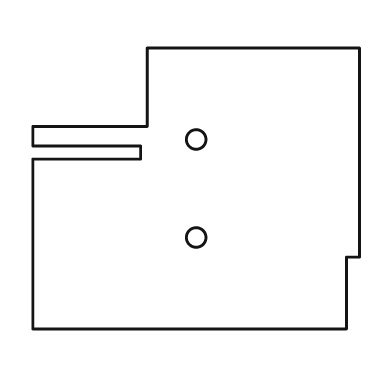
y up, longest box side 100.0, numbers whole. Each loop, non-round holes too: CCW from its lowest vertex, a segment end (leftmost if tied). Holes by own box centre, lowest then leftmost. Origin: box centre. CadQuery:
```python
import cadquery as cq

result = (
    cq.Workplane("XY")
    .moveTo(-50.0, -43.0)
    .lineTo(46.0, -43.0)
    .lineTo(46.0, -21.0)
    .lineTo(50.0, -21.0)
    .lineTo(50.0, 43.0)
    .lineTo(-15.0, 43.0)
    .lineTo(-15.0, 19.0)
    .lineTo(-50.0, 19.0)
    .lineTo(-50.0, 13.0)
    .lineTo(-17.0, 13.0)
    .lineTo(-17.0, 9.0)
    .lineTo(-50.0, 9.0)
    .close()
    .moveTo(0.0, -15.0)
    .circle(3.0)
    .moveTo(0.0, 15.0)
    .circle(3.0)
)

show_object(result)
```